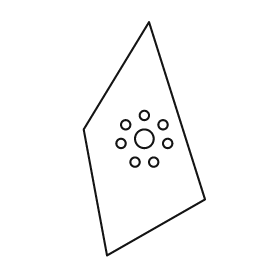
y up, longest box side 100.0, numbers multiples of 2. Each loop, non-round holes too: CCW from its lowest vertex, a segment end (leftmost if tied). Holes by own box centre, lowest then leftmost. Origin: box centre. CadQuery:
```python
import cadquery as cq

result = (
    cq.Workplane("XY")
    .moveTo(-16.0, -50.0)
    .lineTo(26.0, -26.0)
    .lineTo(2.0, 50.0)
    .lineTo(-26.0, 4.0)
    .close()
    .moveTo(-4.0, -10.0)
    .circle(2.0)
    .moveTo(4.0, -10.0)
    .circle(2.0)
    .moveTo(-10.0, -2.0)
    .circle(2.0)
    .moveTo(10.0, -2.0)
    .circle(2.0)
    .moveTo(0.0, 0.0)
    .circle(4.0)
    .moveTo(-8.0, 6.0)
    .circle(2.0)
    .moveTo(8.0, 6.0)
    .circle(2.0)
    .moveTo(0.0, 10.0)
    .circle(2.0)
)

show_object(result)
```